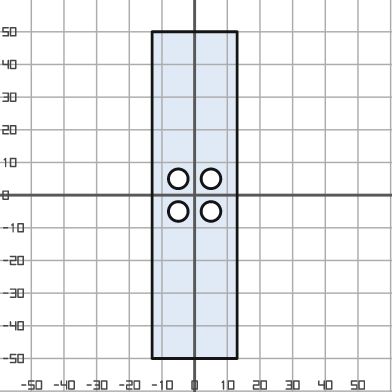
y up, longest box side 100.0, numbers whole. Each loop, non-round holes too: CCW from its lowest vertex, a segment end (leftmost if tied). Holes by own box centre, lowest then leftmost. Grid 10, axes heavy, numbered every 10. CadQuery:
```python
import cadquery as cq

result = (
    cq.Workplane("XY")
    .moveTo(-13.0, -50.0)
    .lineTo(13.0, -50.0)
    .lineTo(13.0, 50.0)
    .lineTo(-13.0, 50.0)
    .close()
    .moveTo(-5.0, -5.0)
    .circle(3.0)
    .moveTo(5.0, -5.0)
    .circle(3.0)
    .moveTo(-5.0, 5.0)
    .circle(3.0)
    .moveTo(5.0, 5.0)
    .circle(3.0)
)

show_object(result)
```